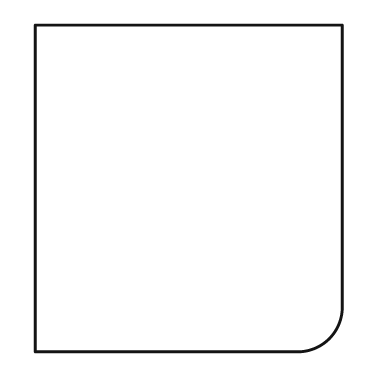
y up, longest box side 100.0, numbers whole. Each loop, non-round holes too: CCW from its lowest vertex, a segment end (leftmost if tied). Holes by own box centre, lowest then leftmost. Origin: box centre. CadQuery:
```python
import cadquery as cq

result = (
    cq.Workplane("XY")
    .moveTo(-47.0, -50.0)
    .lineTo(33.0, -50.0)
    .threePointArc((43.0, -46.0), (47.0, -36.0))
    .lineTo(47.0, 50.0)
    .lineTo(-47.0, 50.0)
    .close()
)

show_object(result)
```